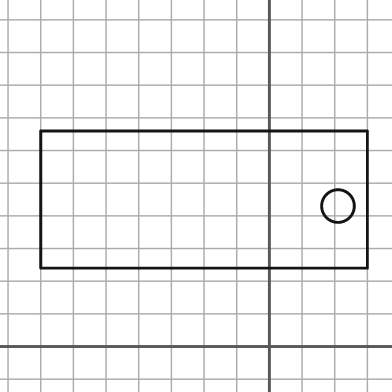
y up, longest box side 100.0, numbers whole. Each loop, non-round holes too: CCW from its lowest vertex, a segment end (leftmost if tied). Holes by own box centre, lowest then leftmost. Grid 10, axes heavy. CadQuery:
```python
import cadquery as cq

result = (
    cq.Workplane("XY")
    .moveTo(-70.0, 24.0)
    .lineTo(30.0, 24.0)
    .lineTo(30.0, 66.0)
    .lineTo(-70.0, 66.0)
    .close()
    .moveTo(21.0, 43.0)
    .circle(5.0)
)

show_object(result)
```